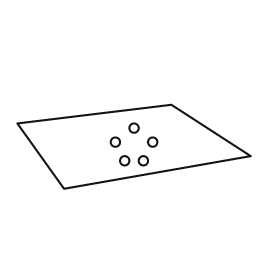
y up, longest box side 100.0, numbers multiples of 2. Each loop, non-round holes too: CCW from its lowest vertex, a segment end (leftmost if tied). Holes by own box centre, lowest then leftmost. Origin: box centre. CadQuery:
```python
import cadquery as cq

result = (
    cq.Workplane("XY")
    .moveTo(-30.0, -18.0)
    .lineTo(50.0, -4.0)
    .lineTo(16.0, 18.0)
    .lineTo(-50.0, 10.0)
    .close()
    .moveTo(-4.0, -6.0)
    .circle(2.0)
    .moveTo(4.0, -6.0)
    .circle(2.0)
    .moveTo(-8.0, 2.0)
    .circle(2.0)
    .moveTo(8.0, 2.0)
    .circle(2.0)
    .moveTo(0.0, 8.0)
    .circle(2.0)
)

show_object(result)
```